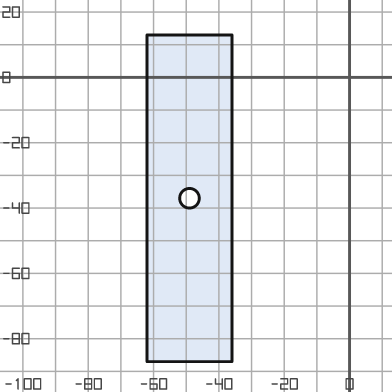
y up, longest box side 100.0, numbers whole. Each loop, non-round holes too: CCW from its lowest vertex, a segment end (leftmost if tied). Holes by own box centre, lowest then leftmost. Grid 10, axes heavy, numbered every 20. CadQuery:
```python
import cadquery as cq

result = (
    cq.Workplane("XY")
    .moveTo(-62.0, -87.0)
    .lineTo(-36.0, -87.0)
    .lineTo(-36.0, 13.0)
    .lineTo(-62.0, 13.0)
    .close()
    .moveTo(-49.0, -37.0)
    .circle(3.0)
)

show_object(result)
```